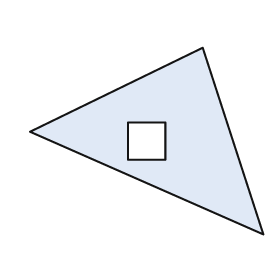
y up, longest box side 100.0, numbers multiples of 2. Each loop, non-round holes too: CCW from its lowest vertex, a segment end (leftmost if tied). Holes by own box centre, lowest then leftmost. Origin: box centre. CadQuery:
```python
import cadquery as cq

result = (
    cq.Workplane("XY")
    .moveTo(50.0, -40.0)
    .lineTo(24.0, 40.0)
    .lineTo(-50.0, 4.0)
    .close()
    .moveTo(-8.0, -8.0)
    .lineTo(8.0, -8.0)
    .lineTo(8.0, 8.0)
    .lineTo(-8.0, 8.0)
    .close()
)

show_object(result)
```